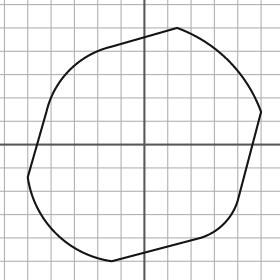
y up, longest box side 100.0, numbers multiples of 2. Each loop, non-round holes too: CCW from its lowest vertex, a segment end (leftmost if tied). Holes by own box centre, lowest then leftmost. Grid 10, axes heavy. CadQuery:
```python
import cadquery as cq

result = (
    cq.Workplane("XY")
    .moveTo(-14.0, -50.0)
    .lineTo(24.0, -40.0)
    .threePointArc((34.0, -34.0), (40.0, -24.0))
    .lineTo(50.0, 14.0)
    .threePointArc((36.0, 36.0), (14.0, 50.0))
    .lineTo(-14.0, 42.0)
    .threePointArc((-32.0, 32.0), (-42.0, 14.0))
    .lineTo(-50.0, -14.0)
    .threePointArc((-38.0, -38.0), (-14.0, -50.0))
    .close()
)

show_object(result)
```